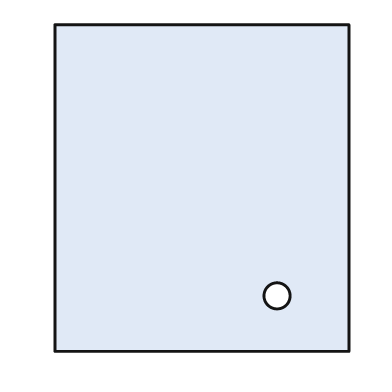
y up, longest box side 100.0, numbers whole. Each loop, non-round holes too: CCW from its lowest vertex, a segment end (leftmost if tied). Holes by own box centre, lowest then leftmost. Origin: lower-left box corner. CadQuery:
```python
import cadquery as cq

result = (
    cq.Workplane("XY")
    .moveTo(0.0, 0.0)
    .lineTo(90.0, 0.0)
    .lineTo(90.0, 100.0)
    .lineTo(0.0, 100.0)
    .close()
    .moveTo(68.0, 17.0)
    .circle(4.0)
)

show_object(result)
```